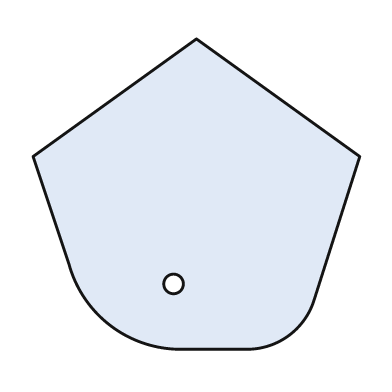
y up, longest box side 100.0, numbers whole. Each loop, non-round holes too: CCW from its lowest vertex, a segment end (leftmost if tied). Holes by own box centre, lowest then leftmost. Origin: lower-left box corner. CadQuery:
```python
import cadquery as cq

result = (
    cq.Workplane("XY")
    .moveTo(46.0, 0.0)
    .lineTo(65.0, 0.0)
    .threePointArc((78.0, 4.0), (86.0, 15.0))
    .lineTo(100.0, 59.0)
    .lineTo(50.0, 95.0)
    .lineTo(0.0, 59.0)
    .lineTo(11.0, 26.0)
    .threePointArc((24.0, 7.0), (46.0, 0.0))
    .close()
    .moveTo(43.0, 20.0)
    .circle(3.0)
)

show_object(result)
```